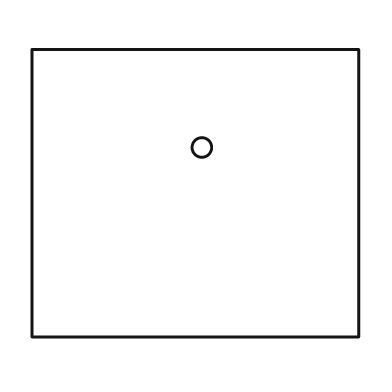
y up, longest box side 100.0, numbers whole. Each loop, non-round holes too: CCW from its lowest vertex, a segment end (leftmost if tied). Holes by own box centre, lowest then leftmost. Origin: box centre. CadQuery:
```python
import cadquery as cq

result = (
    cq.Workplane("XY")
    .moveTo(-50.0, -44.0)
    .lineTo(50.0, -44.0)
    .lineTo(50.0, 44.0)
    .lineTo(-50.0, 44.0)
    .close()
    .moveTo(2.0, 14.0)
    .circle(3.0)
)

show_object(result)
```